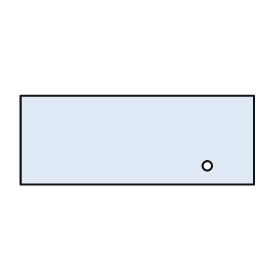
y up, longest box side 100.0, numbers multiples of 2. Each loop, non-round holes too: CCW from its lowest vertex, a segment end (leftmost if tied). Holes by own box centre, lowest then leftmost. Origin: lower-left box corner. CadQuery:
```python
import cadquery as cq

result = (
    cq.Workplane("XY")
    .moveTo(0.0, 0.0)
    .lineTo(100.0, 0.0)
    .lineTo(100.0, 38.0)
    .lineTo(0.0, 38.0)
    .close()
    .moveTo(80.0, 8.0)
    .circle(2.0)
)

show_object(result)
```